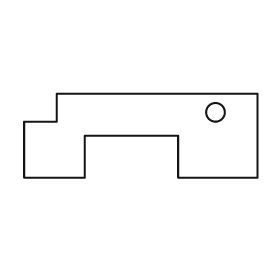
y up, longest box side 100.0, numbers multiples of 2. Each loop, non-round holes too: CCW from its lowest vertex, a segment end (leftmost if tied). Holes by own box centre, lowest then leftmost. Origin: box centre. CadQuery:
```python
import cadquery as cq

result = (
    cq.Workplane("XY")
    .moveTo(-50.0, -18.0)
    .lineTo(-24.0, -18.0)
    .lineTo(-24.0, 0.0)
    .lineTo(16.0, 0.0)
    .lineTo(16.0, -18.0)
    .lineTo(50.0, -18.0)
    .lineTo(50.0, 18.0)
    .lineTo(-36.0, 18.0)
    .lineTo(-36.0, 6.0)
    .lineTo(-50.0, 6.0)
    .close()
    .moveTo(32.0, 10.0)
    .circle(4.0)
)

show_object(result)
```